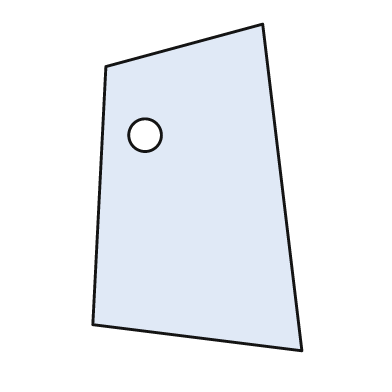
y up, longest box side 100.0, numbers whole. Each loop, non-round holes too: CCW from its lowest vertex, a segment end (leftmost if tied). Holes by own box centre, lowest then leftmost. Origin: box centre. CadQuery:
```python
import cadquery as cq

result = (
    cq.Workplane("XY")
    .moveTo(32.0, -50.0)
    .lineTo(20.0, 50.0)
    .lineTo(-28.0, 37.0)
    .lineTo(-32.0, -42.0)
    .close()
    .moveTo(-16.0, 16.0)
    .circle(5.0)
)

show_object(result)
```